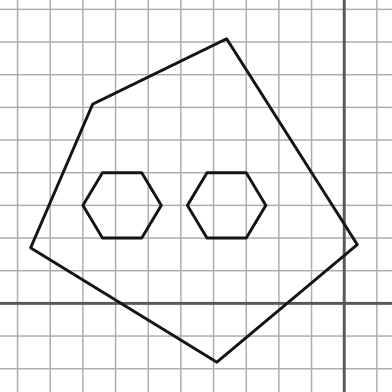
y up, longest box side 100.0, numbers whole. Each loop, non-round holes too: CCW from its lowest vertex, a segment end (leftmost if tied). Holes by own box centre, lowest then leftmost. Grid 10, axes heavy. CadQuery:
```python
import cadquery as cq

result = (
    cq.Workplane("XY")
    .moveTo(-39.0, -18.0)
    .lineTo(4.0, 18.0)
    .lineTo(-36.0, 81.0)
    .lineTo(-77.0, 61.0)
    .lineTo(-96.0, 17.0)
    .close()
    .moveTo(-74.0, 20.0)
    .lineTo(-62.0, 20.0)
    .lineTo(-56.0, 30.0)
    .lineTo(-62.0, 40.0)
    .lineTo(-74.0, 40.0)
    .lineTo(-80.0, 30.0)
    .close()
    .moveTo(-42.0, 20.0)
    .lineTo(-30.0, 20.0)
    .lineTo(-24.0, 30.0)
    .lineTo(-30.0, 40.0)
    .lineTo(-42.0, 40.0)
    .lineTo(-48.0, 30.0)
    .close()
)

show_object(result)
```